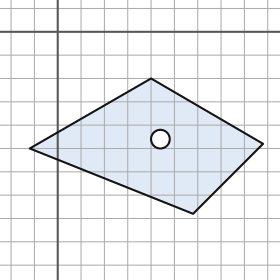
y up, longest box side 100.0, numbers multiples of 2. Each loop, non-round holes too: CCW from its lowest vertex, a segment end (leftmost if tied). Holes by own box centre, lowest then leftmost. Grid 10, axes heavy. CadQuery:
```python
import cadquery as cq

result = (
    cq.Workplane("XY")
    .moveTo(58.0, -78.0)
    .lineTo(88.0, -48.0)
    .lineTo(40.0, -20.0)
    .lineTo(-12.0, -50.0)
    .close()
    .moveTo(44.0, -46.0)
    .circle(4.0)
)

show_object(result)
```